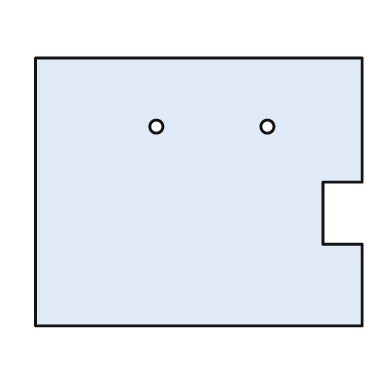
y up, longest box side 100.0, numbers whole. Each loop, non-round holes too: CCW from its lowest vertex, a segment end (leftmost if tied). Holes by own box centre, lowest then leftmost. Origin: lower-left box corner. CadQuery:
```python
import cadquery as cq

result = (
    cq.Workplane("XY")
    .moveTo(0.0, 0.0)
    .lineTo(100.0, 0.0)
    .lineTo(100.0, 25.0)
    .lineTo(88.0, 25.0)
    .lineTo(88.0, 44.0)
    .lineTo(100.0, 44.0)
    .lineTo(100.0, 82.0)
    .lineTo(0.0, 82.0)
    .close()
    .moveTo(37.0, 61.0)
    .circle(2.0)
    .moveTo(71.0, 61.0)
    .circle(2.0)
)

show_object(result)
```